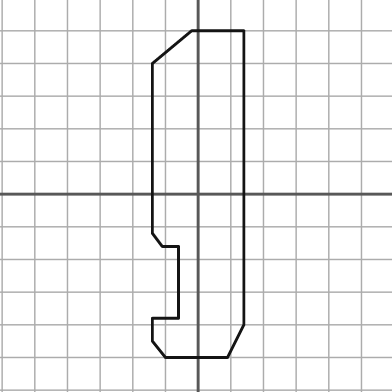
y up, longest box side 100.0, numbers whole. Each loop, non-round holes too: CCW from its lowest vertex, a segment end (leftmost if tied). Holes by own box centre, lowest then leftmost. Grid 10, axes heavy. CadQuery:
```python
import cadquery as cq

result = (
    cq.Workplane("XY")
    .moveTo(-10.0, -50.0)
    .lineTo(9.0, -50.0)
    .lineTo(14.0, -40.0)
    .lineTo(14.0, 50.0)
    .lineTo(-2.0, 50.0)
    .lineTo(-14.0, 40.0)
    .lineTo(-14.0, -12.0)
    .lineTo(-11.0, -16.0)
    .lineTo(-6.0, -16.0)
    .lineTo(-6.0, -38.0)
    .lineTo(-14.0, -38.0)
    .lineTo(-14.0, -45.0)
    .close()
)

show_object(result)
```